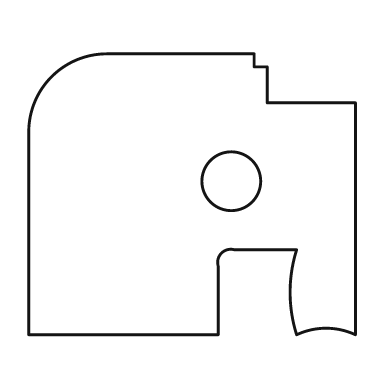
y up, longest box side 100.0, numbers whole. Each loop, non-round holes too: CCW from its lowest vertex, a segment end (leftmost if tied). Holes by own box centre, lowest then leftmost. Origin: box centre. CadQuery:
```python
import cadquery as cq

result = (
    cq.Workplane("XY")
    .moveTo(-50.0, -43.0)
    .lineTo(8.0, -43.0)
    .lineTo(8.0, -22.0)
    .threePointArc((9.0, -18.0), (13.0, -17.0))
    .lineTo(32.0, -17.0)
    .threePointArc((30.0, -30.0), (32.0, -43.0))
    .threePointArc((41.0, -41.0), (50.0, -43.0))
    .lineTo(50.0, 28.0)
    .lineTo(23.0, 28.0)
    .lineTo(23.0, 39.0)
    .lineTo(19.0, 39.0)
    .lineTo(19.0, 43.0)
    .lineTo(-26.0, 43.0)
    .threePointArc((-43.0, 36.0), (-50.0, 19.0))
    .close()
    .moveTo(12.0, 4.0)
    .circle(9.0)
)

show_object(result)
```